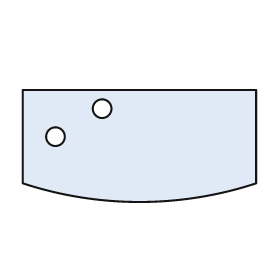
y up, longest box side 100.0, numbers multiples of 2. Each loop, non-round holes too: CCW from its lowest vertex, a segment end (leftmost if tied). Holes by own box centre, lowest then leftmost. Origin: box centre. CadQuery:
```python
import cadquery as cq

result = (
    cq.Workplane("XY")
    .moveTo(-50.0, -16.0)
    .threePointArc((0.0, -24.0), (50.0, -16.0))
    .lineTo(50.0, 24.0)
    .lineTo(-50.0, 24.0)
    .close()
    .moveTo(-36.0, 4.0)
    .circle(4.0)
    .moveTo(-16.0, 16.0)
    .circle(4.0)
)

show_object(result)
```